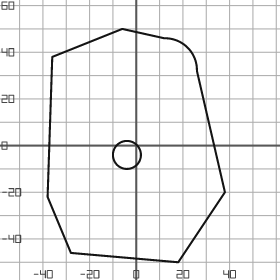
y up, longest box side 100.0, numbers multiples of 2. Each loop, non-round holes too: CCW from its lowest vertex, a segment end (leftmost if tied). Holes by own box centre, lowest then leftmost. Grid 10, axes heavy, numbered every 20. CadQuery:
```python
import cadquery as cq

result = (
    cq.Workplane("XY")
    .moveTo(18.0, -50.0)
    .lineTo(38.0, -20.0)
    .lineTo(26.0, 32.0)
    .threePointArc((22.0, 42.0), (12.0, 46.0))
    .lineTo(-6.0, 50.0)
    .lineTo(-36.0, 38.0)
    .lineTo(-38.0, -22.0)
    .lineTo(-28.0, -46.0)
    .close()
    .moveTo(-4.0, -4.0)
    .circle(6.0)
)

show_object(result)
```